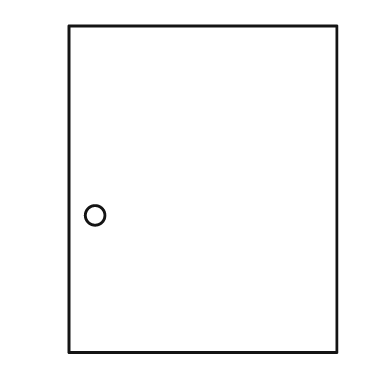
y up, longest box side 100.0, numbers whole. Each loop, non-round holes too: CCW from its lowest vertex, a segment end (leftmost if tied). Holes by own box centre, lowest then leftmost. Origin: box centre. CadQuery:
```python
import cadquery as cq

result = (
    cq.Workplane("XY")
    .moveTo(-41.0, -50.0)
    .lineTo(41.0, -50.0)
    .lineTo(41.0, 50.0)
    .lineTo(-41.0, 50.0)
    .close()
    .moveTo(-33.0, -8.0)
    .circle(3.0)
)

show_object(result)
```